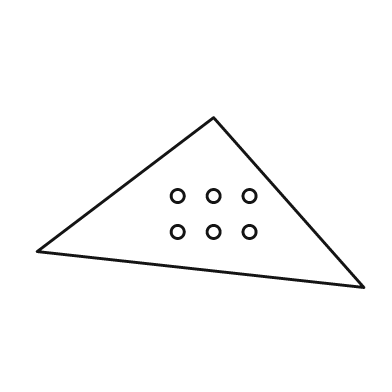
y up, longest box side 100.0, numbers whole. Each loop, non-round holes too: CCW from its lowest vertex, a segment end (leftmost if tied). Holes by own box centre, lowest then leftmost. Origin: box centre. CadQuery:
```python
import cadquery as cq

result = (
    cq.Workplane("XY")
    .moveTo(50.0, -26.0)
    .lineTo(4.0, 26.0)
    .lineTo(-50.0, -15.0)
    .close()
    .moveTo(-7.0, -9.0)
    .circle(2.0)
    .moveTo(4.0, -9.0)
    .circle(2.0)
    .moveTo(15.0, -9.0)
    .circle(2.0)
    .moveTo(-7.0, 2.0)
    .circle(2.0)
    .moveTo(4.0, 2.0)
    .circle(2.0)
    .moveTo(15.0, 2.0)
    .circle(2.0)
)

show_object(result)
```